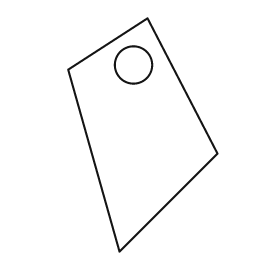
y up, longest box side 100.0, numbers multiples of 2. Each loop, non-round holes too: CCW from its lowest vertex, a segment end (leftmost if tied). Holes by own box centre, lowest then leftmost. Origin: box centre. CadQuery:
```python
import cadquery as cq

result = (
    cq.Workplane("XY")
    .moveTo(-10.0, -50.0)
    .lineTo(32.0, -8.0)
    .lineTo(2.0, 50.0)
    .lineTo(-32.0, 28.0)
    .close()
    .moveTo(-4.0, 30.0)
    .circle(8.0)
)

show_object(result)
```